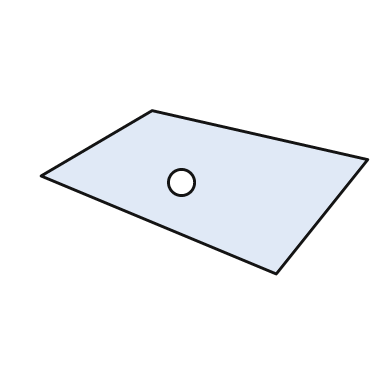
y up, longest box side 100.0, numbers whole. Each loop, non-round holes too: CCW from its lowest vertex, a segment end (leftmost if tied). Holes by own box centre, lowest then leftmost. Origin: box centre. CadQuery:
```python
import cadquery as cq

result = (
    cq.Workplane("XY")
    .moveTo(22.0, -25.0)
    .lineTo(50.0, 10.0)
    .lineTo(-16.0, 25.0)
    .lineTo(-50.0, 5.0)
    .close()
    .moveTo(-7.0, 3.0)
    .circle(4.0)
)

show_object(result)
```